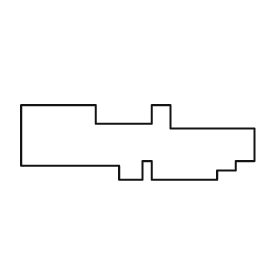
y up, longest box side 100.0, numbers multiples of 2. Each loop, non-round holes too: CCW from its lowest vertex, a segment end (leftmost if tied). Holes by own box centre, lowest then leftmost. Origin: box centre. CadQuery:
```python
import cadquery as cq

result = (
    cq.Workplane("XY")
    .moveTo(-8.0, -16.0)
    .lineTo(2.0, -16.0)
    .lineTo(2.0, -8.0)
    .lineTo(6.0, -8.0)
    .lineTo(6.0, -16.0)
    .lineTo(34.0, -16.0)
    .lineTo(34.0, -12.0)
    .lineTo(42.0, -12.0)
    .lineTo(42.0, -8.0)
    .lineTo(50.0, -8.0)
    .lineTo(50.0, 6.0)
    .lineTo(14.0, 6.0)
    .lineTo(14.0, 16.0)
    .lineTo(6.0, 16.0)
    .lineTo(6.0, 8.0)
    .lineTo(-18.0, 8.0)
    .lineTo(-18.0, 16.0)
    .lineTo(-50.0, 16.0)
    .lineTo(-50.0, -10.0)
    .lineTo(-8.0, -10.0)
    .close()
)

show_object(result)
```